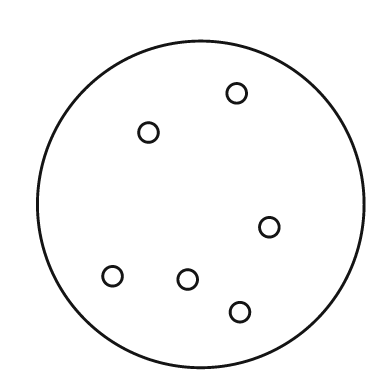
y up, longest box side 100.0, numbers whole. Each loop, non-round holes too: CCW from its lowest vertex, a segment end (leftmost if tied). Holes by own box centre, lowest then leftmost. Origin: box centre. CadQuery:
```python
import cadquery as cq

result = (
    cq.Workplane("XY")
    .moveTo(0.0, 0.0)
    .circle(50.0)
    .moveTo(12.0, -33.0)
    .circle(3.0)
    .moveTo(-4.0, -23.0)
    .circle(3.0)
    .moveTo(-27.0, -22.0)
    .circle(3.0)
    .moveTo(21.0, -7.0)
    .circle(3.0)
    .moveTo(-16.0, 22.0)
    .circle(3.0)
    .moveTo(11.0, 34.0)
    .circle(3.0)
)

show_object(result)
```